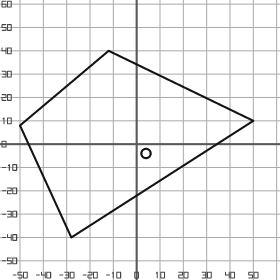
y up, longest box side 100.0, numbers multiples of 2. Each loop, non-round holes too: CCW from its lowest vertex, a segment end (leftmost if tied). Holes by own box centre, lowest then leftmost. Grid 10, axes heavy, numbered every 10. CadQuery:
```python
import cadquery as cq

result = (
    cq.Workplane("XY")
    .moveTo(-28.0, -40.0)
    .lineTo(50.0, 10.0)
    .lineTo(-12.0, 40.0)
    .lineTo(-50.0, 8.0)
    .close()
    .moveTo(4.0, -4.0)
    .circle(2.0)
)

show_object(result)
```